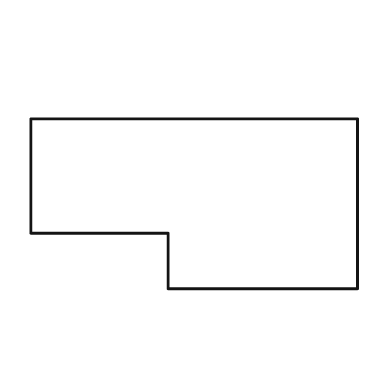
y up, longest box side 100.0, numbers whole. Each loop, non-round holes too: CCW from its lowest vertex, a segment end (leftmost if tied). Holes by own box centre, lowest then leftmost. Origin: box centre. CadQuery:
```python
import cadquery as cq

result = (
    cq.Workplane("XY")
    .moveTo(-8.0, -26.0)
    .lineTo(50.0, -26.0)
    .lineTo(50.0, 26.0)
    .lineTo(-50.0, 26.0)
    .lineTo(-50.0, -9.0)
    .lineTo(-8.0, -9.0)
    .close()
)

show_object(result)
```